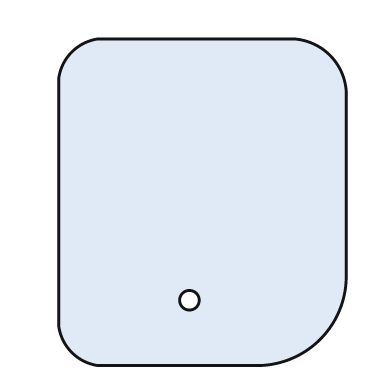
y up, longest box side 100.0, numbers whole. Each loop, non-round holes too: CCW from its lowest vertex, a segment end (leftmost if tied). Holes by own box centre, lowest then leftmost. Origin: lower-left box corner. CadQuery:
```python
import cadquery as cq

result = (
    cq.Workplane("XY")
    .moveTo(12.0, 0.0)
    .lineTo(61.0, 0.0)
    .threePointArc((80.0, 8.0), (88.0, 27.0))
    .lineTo(88.0, 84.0)
    .threePointArc((83.0, 95.0), (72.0, 100.0))
    .lineTo(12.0, 100.0)
    .threePointArc((4.0, 96.0), (0.0, 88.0))
    .lineTo(0.0, 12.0)
    .threePointArc((4.0, 4.0), (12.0, 0.0))
    .close()
    .moveTo(40.0, 20.0)
    .circle(3.0)
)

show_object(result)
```